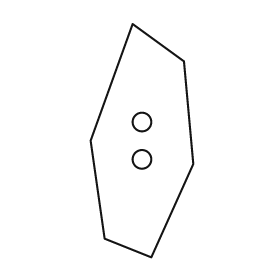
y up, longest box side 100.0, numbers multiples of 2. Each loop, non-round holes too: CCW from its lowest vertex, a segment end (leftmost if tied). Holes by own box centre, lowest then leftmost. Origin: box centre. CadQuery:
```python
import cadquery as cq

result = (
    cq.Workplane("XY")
    .moveTo(4.0, -50.0)
    .lineTo(22.0, -10.0)
    .lineTo(18.0, 34.0)
    .lineTo(-4.0, 50.0)
    .lineTo(-22.0, 0.0)
    .lineTo(-16.0, -42.0)
    .close()
    .moveTo(0.0, -8.0)
    .circle(4.0)
    .moveTo(0.0, 8.0)
    .circle(4.0)
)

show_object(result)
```